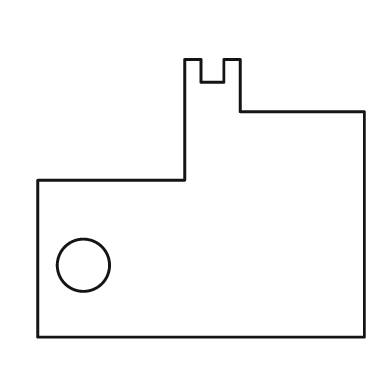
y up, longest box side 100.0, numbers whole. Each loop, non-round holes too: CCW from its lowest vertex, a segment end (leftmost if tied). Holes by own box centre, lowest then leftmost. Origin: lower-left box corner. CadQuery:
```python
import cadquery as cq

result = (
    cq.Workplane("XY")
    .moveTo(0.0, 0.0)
    .lineTo(100.0, 0.0)
    .lineTo(100.0, 69.0)
    .lineTo(62.0, 69.0)
    .lineTo(62.0, 85.0)
    .lineTo(57.0, 85.0)
    .lineTo(57.0, 78.0)
    .lineTo(50.0, 78.0)
    .lineTo(50.0, 85.0)
    .lineTo(45.0, 85.0)
    .lineTo(45.0, 48.0)
    .lineTo(0.0, 48.0)
    .close()
    .moveTo(14.0, 22.0)
    .circle(8.0)
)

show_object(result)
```